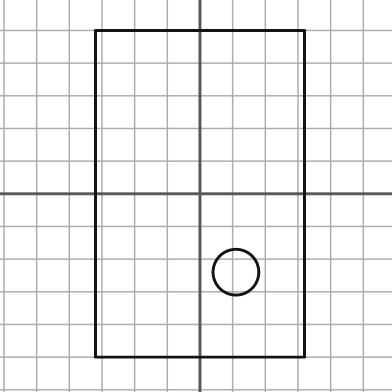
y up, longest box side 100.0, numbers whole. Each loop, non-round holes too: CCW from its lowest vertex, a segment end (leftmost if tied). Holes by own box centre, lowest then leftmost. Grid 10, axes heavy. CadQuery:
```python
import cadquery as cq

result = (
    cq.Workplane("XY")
    .moveTo(-32.0, -50.0)
    .lineTo(32.0, -50.0)
    .lineTo(32.0, 50.0)
    .lineTo(-32.0, 50.0)
    .close()
    .moveTo(11.0, -24.0)
    .circle(7.0)
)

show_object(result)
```